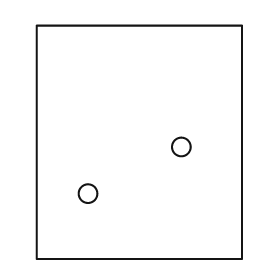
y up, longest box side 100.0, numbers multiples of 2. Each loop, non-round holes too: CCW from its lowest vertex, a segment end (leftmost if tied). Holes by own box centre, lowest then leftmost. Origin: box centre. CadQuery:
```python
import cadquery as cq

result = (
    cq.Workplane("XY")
    .moveTo(-44.0, -50.0)
    .lineTo(44.0, -50.0)
    .lineTo(44.0, 50.0)
    .lineTo(-44.0, 50.0)
    .close()
    .moveTo(-22.0, -22.0)
    .circle(4.0)
    .moveTo(18.0, -2.0)
    .circle(4.0)
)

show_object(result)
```